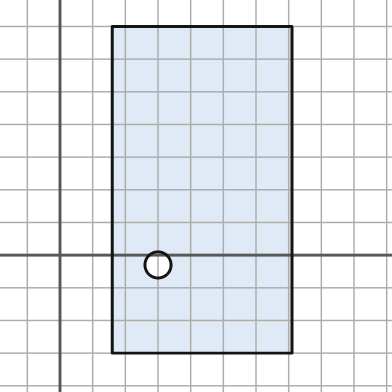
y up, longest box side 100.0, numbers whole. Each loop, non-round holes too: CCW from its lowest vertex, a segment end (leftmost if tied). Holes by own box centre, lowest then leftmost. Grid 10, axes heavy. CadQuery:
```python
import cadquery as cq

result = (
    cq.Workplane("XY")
    .moveTo(16.0, -30.0)
    .lineTo(71.0, -30.0)
    .lineTo(71.0, 70.0)
    .lineTo(16.0, 70.0)
    .close()
    .moveTo(30.0, -3.0)
    .circle(4.0)
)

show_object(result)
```